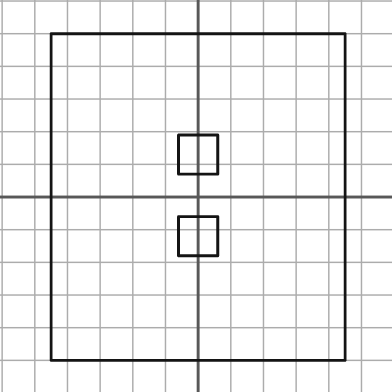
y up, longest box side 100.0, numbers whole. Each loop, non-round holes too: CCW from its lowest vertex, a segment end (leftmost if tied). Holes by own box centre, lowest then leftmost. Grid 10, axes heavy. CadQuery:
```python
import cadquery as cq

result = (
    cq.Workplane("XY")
    .moveTo(-45.0, -50.0)
    .lineTo(45.0, -50.0)
    .lineTo(45.0, 50.0)
    .lineTo(-45.0, 50.0)
    .close()
    .moveTo(-6.0, -18.0)
    .lineTo(6.0, -18.0)
    .lineTo(6.0, -6.0)
    .lineTo(-6.0, -6.0)
    .close()
    .moveTo(-6.0, 7.0)
    .lineTo(6.0, 7.0)
    .lineTo(6.0, 19.0)
    .lineTo(-6.0, 19.0)
    .close()
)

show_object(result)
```